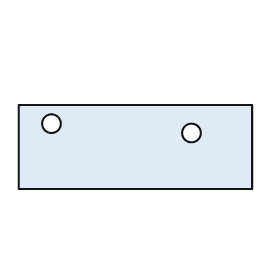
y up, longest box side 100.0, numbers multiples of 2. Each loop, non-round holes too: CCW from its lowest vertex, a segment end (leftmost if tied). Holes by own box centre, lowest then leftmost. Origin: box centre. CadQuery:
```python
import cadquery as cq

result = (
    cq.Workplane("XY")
    .moveTo(-50.0, -18.0)
    .lineTo(50.0, -18.0)
    .lineTo(50.0, 18.0)
    .lineTo(-50.0, 18.0)
    .close()
    .moveTo(24.0, 6.0)
    .circle(4.0)
    .moveTo(-36.0, 10.0)
    .circle(4.0)
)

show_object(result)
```